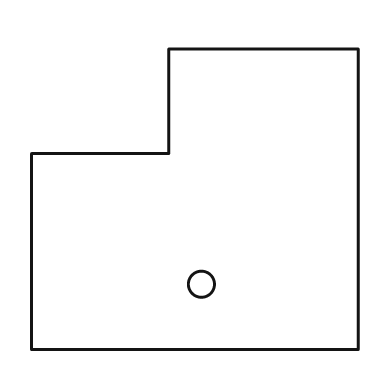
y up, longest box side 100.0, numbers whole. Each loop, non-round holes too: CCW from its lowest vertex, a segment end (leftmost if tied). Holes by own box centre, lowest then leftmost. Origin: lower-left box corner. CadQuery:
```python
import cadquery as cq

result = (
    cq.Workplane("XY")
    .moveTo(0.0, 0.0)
    .lineTo(100.0, 0.0)
    .lineTo(100.0, 92.0)
    .lineTo(42.0, 92.0)
    .lineTo(42.0, 60.0)
    .lineTo(0.0, 60.0)
    .close()
    .moveTo(52.0, 20.0)
    .circle(4.0)
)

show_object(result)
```